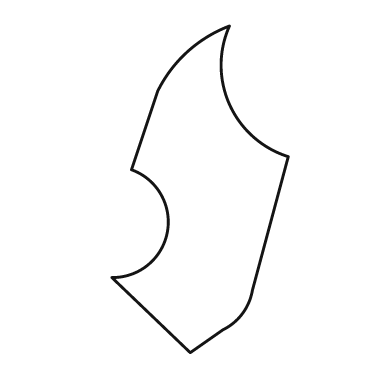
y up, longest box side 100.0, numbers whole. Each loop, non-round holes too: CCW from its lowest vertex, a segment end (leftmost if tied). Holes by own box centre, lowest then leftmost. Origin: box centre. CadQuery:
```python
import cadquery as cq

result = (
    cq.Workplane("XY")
    .moveTo(-3.0, -50.0)
    .lineTo(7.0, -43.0)
    .threePointArc((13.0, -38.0), (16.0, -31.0))
    .lineTo(27.0, 10.0)
    .threePointArc((9.0, 26.0), (9.0, 50.0))
    .threePointArc((-4.0, 42.0), (-13.0, 30.0))
    .lineTo(-21.0, 6.0)
    .threePointArc((-10.0, -13.0), (-27.0, -27.0))
    .close()
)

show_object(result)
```